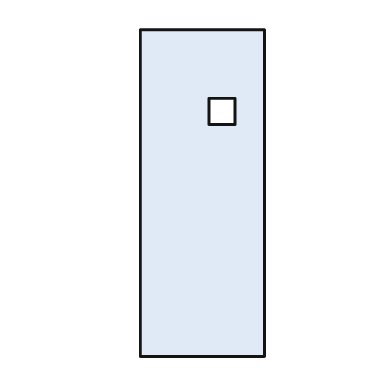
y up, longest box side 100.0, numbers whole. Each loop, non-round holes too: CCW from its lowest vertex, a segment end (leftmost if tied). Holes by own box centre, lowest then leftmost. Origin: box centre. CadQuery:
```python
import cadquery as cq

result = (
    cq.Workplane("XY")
    .moveTo(-19.0, -50.0)
    .lineTo(19.0, -50.0)
    .lineTo(19.0, 50.0)
    .lineTo(-19.0, 50.0)
    .close()
    .moveTo(2.0, 21.0)
    .lineTo(10.0, 21.0)
    .lineTo(10.0, 29.0)
    .lineTo(2.0, 29.0)
    .close()
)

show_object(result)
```